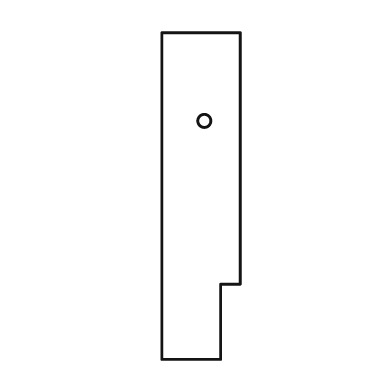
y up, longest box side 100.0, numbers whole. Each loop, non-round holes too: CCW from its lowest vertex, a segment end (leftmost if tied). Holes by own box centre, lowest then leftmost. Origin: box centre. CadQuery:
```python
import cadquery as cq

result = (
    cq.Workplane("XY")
    .moveTo(-12.0, -50.0)
    .lineTo(6.0, -50.0)
    .lineTo(6.0, -27.0)
    .lineTo(12.0, -27.0)
    .lineTo(12.0, 50.0)
    .lineTo(-12.0, 50.0)
    .close()
    .moveTo(1.0, 23.0)
    .circle(2.0)
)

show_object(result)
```